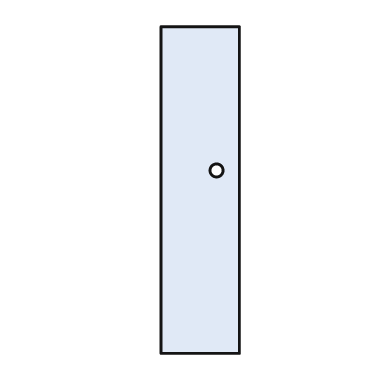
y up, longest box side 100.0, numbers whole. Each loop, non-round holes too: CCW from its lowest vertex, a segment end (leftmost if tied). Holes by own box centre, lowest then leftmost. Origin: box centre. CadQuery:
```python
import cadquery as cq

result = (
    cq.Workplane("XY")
    .moveTo(-12.0, -50.0)
    .lineTo(12.0, -50.0)
    .lineTo(12.0, 50.0)
    .lineTo(-12.0, 50.0)
    .close()
    .moveTo(5.0, 6.0)
    .circle(2.0)
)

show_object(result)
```